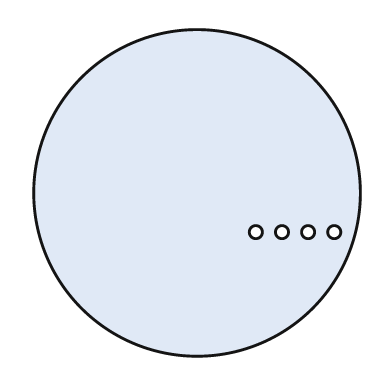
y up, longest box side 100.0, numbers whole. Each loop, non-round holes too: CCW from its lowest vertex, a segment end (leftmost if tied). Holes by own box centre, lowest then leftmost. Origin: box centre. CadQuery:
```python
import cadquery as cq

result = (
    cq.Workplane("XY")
    .moveTo(0.0, 0.0)
    .circle(50.0)
    .moveTo(18.0, -12.0)
    .circle(2.0)
    .moveTo(26.0, -12.0)
    .circle(2.0)
    .moveTo(34.0, -12.0)
    .circle(2.0)
    .moveTo(42.0, -12.0)
    .circle(2.0)
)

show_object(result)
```